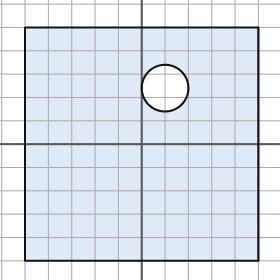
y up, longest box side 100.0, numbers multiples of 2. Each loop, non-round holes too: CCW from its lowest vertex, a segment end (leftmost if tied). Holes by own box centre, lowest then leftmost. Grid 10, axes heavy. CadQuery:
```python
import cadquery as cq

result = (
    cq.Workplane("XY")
    .moveTo(-50.0, -50.0)
    .lineTo(50.0, -50.0)
    .lineTo(50.0, 50.0)
    .lineTo(-50.0, 50.0)
    .close()
    .moveTo(10.0, 24.0)
    .circle(10.0)
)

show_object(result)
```